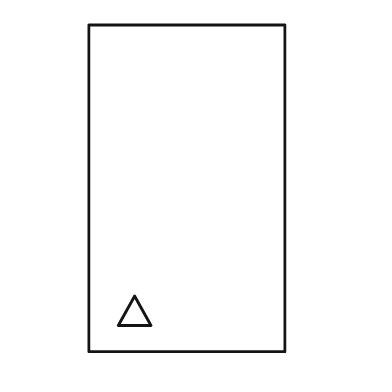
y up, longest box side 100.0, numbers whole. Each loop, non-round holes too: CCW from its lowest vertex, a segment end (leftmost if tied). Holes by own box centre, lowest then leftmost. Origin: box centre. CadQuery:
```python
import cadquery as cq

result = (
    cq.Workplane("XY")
    .moveTo(-30.0, -50.0)
    .lineTo(30.0, -50.0)
    .lineTo(30.0, 50.0)
    .lineTo(-30.0, 50.0)
    .close()
    .moveTo(-21.0, -42.0)
    .lineTo(-11.0, -42.0)
    .lineTo(-16.0, -33.0)
    .close()
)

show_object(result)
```